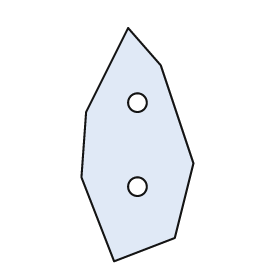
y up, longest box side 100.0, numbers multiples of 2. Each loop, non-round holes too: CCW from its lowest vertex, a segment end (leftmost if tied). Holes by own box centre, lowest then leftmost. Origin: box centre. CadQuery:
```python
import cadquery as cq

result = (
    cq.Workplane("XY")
    .moveTo(-10.0, -50.0)
    .lineTo(16.0, -40.0)
    .lineTo(24.0, -8.0)
    .lineTo(10.0, 34.0)
    .lineTo(-4.0, 50.0)
    .lineTo(-22.0, 14.0)
    .lineTo(-24.0, -14.0)
    .close()
    .moveTo(0.0, -18.0)
    .circle(4.0)
    .moveTo(0.0, 18.0)
    .circle(4.0)
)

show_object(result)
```